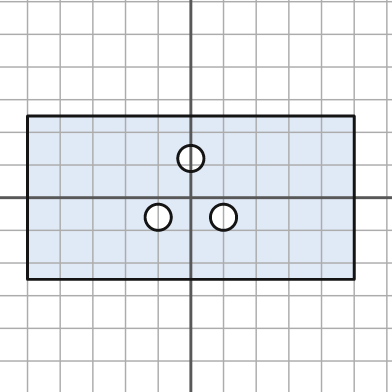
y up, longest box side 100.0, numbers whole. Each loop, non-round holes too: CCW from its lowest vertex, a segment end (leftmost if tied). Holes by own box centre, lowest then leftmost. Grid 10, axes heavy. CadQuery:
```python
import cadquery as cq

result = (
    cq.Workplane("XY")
    .moveTo(-50.0, -25.0)
    .lineTo(50.0, -25.0)
    .lineTo(50.0, 25.0)
    .lineTo(-50.0, 25.0)
    .close()
    .moveTo(-10.0, -6.0)
    .circle(4.0)
    .moveTo(10.0, -6.0)
    .circle(4.0)
    .moveTo(0.0, 12.0)
    .circle(4.0)
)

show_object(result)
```